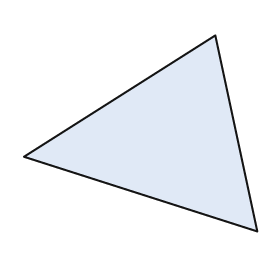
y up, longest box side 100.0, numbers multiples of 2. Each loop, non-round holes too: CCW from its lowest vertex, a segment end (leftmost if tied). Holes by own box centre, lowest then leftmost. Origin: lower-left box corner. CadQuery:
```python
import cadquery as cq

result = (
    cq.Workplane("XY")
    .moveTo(100.0, 0.0)
    .lineTo(82.0, 84.0)
    .lineTo(0.0, 32.0)
    .close()
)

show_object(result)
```